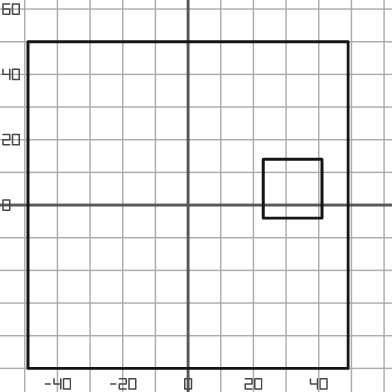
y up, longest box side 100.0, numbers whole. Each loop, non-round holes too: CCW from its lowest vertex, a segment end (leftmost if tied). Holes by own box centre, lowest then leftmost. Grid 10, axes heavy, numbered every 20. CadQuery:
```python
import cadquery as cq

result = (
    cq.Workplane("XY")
    .moveTo(-49.0, -50.0)
    .lineTo(49.0, -50.0)
    .lineTo(49.0, 50.0)
    .lineTo(-49.0, 50.0)
    .close()
    .moveTo(23.0, -4.0)
    .lineTo(41.0, -4.0)
    .lineTo(41.0, 14.0)
    .lineTo(23.0, 14.0)
    .close()
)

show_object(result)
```